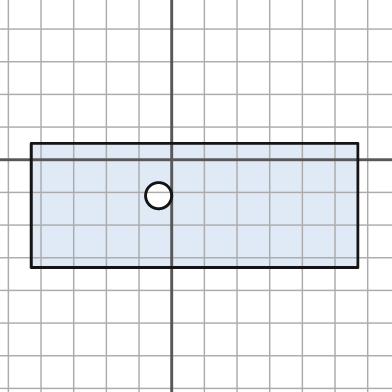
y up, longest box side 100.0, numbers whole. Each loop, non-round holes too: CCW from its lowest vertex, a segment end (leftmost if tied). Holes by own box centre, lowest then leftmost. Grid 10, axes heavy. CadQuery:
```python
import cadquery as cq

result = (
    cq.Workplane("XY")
    .moveTo(-43.0, -33.0)
    .lineTo(57.0, -33.0)
    .lineTo(57.0, 5.0)
    .lineTo(-43.0, 5.0)
    .close()
    .moveTo(-4.0, -11.0)
    .circle(4.0)
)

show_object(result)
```